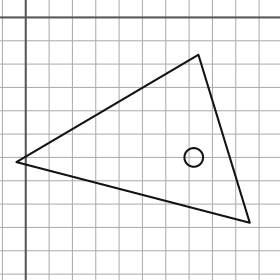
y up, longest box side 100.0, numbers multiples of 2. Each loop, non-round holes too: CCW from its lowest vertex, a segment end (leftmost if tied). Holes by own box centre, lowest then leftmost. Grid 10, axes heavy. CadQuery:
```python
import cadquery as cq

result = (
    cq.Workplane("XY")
    .moveTo(96.0, -88.0)
    .lineTo(74.0, -16.0)
    .lineTo(-4.0, -62.0)
    .close()
    .moveTo(72.0, -60.0)
    .circle(4.0)
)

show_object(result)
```